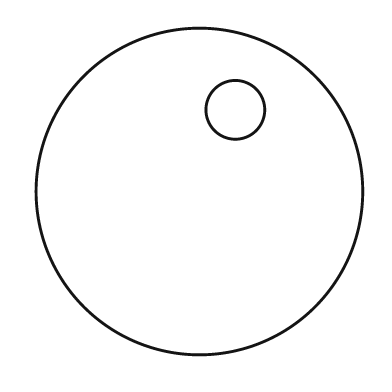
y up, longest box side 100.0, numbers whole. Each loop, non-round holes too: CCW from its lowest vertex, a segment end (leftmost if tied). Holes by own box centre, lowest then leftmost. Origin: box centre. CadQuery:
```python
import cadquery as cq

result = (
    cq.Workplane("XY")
    .moveTo(0.0, 0.0)
    .circle(50.0)
    .moveTo(11.0, 25.0)
    .circle(9.0)
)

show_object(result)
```